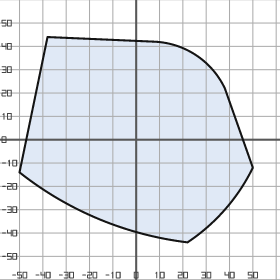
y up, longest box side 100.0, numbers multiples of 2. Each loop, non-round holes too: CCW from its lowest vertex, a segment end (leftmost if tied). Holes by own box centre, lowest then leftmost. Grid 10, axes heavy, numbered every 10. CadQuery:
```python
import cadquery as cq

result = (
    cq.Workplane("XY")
    .moveTo(22.0, -44.0)
    .threePointArc((38.0, -30.0), (50.0, -12.0))
    .lineTo(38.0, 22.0)
    .threePointArc((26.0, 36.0), (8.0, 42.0))
    .lineTo(-38.0, 44.0)
    .lineTo(-50.0, -14.0)
    .threePointArc((-16.0, -34.0), (22.0, -44.0))
    .close()
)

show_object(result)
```